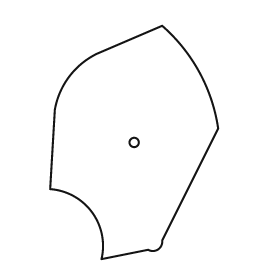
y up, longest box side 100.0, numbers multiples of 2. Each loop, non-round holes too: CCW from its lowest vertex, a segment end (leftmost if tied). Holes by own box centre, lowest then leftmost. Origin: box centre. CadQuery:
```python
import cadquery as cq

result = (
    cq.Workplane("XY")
    .moveTo(-14.0, -50.0)
    .lineTo(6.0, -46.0)
    .threePointArc((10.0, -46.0), (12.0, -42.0))
    .lineTo(36.0, 6.0)
    .threePointArc((28.0, 30.0), (12.0, 50.0))
    .lineTo(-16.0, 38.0)
    .threePointArc((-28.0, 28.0), (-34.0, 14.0))
    .lineTo(-36.0, -20.0)
    .threePointArc((-18.0, -30.0), (-14.0, -50.0))
    .close()
    .moveTo(0.0, 0.0)
    .circle(2.0)
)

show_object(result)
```